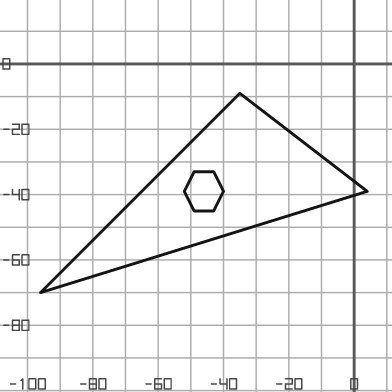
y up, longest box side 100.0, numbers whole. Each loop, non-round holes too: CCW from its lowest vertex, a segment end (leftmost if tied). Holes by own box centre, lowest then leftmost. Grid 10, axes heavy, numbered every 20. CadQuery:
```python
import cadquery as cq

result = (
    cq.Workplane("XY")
    .moveTo(-96.0, -70.0)
    .lineTo(4.0, -39.0)
    .lineTo(-35.0, -9.0)
    .close()
    .moveTo(-49.0, -45.0)
    .lineTo(-43.0, -45.0)
    .lineTo(-40.0, -39.0)
    .lineTo(-43.0, -33.0)
    .lineTo(-49.0, -33.0)
    .lineTo(-52.0, -39.0)
    .close()
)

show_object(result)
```